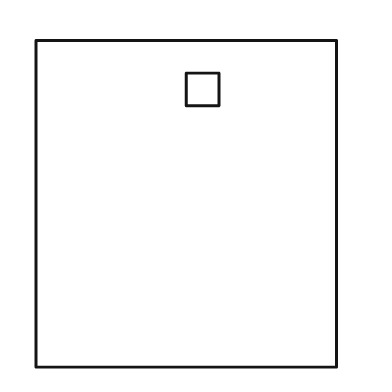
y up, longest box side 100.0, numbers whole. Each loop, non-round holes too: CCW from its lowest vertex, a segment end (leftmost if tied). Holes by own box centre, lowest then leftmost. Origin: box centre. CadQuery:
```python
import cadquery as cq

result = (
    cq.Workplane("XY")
    .moveTo(-46.0, -50.0)
    .lineTo(46.0, -50.0)
    .lineTo(46.0, 50.0)
    .lineTo(-46.0, 50.0)
    .close()
    .moveTo(0.0, 30.0)
    .lineTo(10.0, 30.0)
    .lineTo(10.0, 40.0)
    .lineTo(0.0, 40.0)
    .close()
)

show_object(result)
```